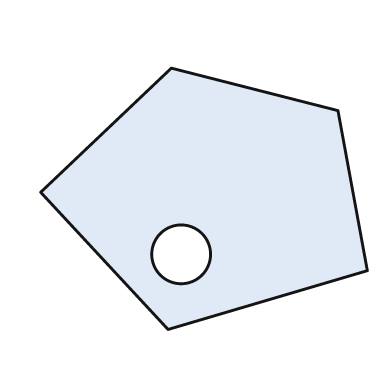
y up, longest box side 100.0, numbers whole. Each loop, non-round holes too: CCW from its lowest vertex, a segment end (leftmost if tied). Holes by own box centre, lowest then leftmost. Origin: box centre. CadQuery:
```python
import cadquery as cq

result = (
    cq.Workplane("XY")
    .moveTo(-11.0, -40.0)
    .lineTo(50.0, -22.0)
    .lineTo(41.0, 27.0)
    .lineTo(-10.0, 40.0)
    .lineTo(-50.0, 2.0)
    .close()
    .moveTo(-7.0, -17.0)
    .circle(9.0)
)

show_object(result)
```